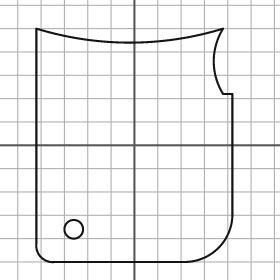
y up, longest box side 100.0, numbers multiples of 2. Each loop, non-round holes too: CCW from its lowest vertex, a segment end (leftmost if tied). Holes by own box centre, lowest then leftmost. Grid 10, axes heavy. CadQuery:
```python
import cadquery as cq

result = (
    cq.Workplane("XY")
    .moveTo(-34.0, -50.0)
    .lineTo(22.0, -50.0)
    .threePointArc((36.0, -44.0), (42.0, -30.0))
    .lineTo(42.0, 22.0)
    .lineTo(38.0, 22.0)
    .threePointArc((34.0, 36.0), (38.0, 50.0))
    .threePointArc((-2.0, 44.0), (-42.0, 50.0))
    .lineTo(-42.0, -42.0)
    .threePointArc((-40.0, -48.0), (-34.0, -50.0))
    .close()
    .moveTo(-26.0, -36.0)
    .circle(4.0)
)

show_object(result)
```